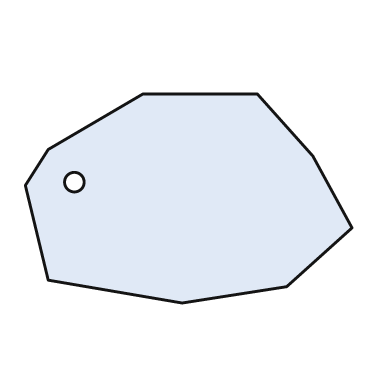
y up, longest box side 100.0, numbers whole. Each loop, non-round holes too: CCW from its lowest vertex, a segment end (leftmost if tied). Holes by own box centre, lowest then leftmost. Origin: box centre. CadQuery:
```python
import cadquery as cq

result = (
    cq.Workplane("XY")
    .moveTo(-2.0, -32.0)
    .lineTo(30.0, -27.0)
    .lineTo(50.0, -9.0)
    .lineTo(38.0, 13.0)
    .lineTo(21.0, 32.0)
    .lineTo(-14.0, 32.0)
    .lineTo(-43.0, 15.0)
    .lineTo(-50.0, 4.0)
    .lineTo(-43.0, -25.0)
    .close()
    .moveTo(-35.0, 5.0)
    .circle(3.0)
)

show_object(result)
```